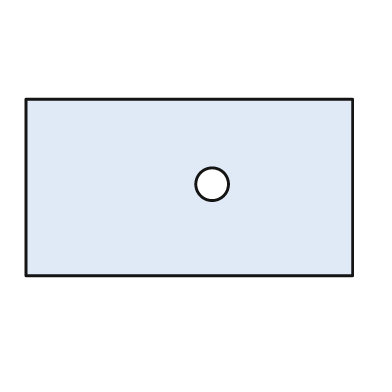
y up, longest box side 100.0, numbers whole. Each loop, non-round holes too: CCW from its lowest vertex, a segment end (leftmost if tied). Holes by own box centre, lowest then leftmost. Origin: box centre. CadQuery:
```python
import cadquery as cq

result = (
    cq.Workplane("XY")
    .moveTo(-50.0, -27.0)
    .lineTo(50.0, -27.0)
    .lineTo(50.0, 27.0)
    .lineTo(-50.0, 27.0)
    .close()
    .moveTo(7.0, 1.0)
    .circle(5.0)
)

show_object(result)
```